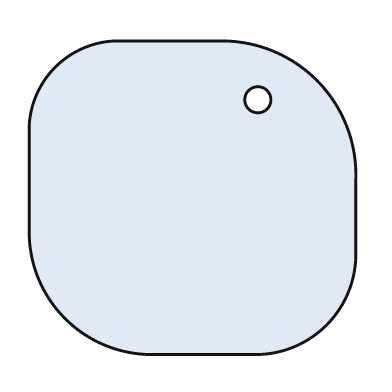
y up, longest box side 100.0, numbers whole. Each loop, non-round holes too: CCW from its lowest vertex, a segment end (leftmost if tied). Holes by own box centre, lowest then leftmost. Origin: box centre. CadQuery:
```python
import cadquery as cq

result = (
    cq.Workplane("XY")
    .moveTo(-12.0, -48.0)
    .lineTo(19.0, -48.0)
    .threePointArc((41.0, -39.0), (50.0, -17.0))
    .lineTo(50.0, 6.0)
    .threePointArc((38.0, 36.0), (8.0, 48.0))
    .lineTo(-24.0, 48.0)
    .threePointArc((-42.0, 40.0), (-50.0, 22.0))
    .lineTo(-50.0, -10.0)
    .threePointArc((-39.0, -37.0), (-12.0, -48.0))
    .close()
    .moveTo(20.0, 30.0)
    .circle(4.0)
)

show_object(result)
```